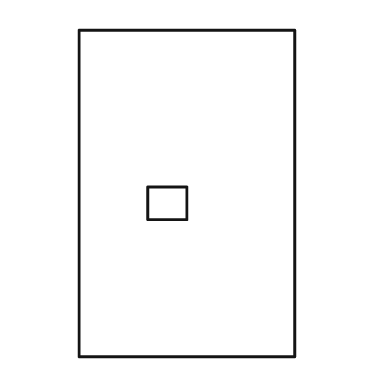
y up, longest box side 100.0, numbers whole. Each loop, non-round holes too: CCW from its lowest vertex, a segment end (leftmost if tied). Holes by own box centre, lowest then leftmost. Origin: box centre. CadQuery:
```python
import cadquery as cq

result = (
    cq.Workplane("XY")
    .moveTo(-33.0, -50.0)
    .lineTo(33.0, -50.0)
    .lineTo(33.0, 50.0)
    .lineTo(-33.0, 50.0)
    .close()
    .moveTo(-12.0, -8.0)
    .lineTo(0.0, -8.0)
    .lineTo(0.0, 2.0)
    .lineTo(-12.0, 2.0)
    .close()
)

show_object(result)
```